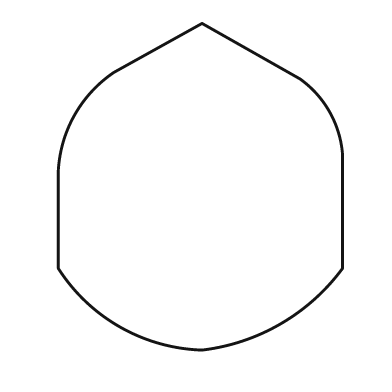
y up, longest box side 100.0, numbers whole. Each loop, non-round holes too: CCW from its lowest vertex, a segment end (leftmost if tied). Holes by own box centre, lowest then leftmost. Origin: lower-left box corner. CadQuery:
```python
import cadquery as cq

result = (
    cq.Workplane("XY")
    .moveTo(44.0, 0.0)
    .threePointArc((68.0, 8.0), (87.0, 25.0))
    .lineTo(87.0, 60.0)
    .threePointArc((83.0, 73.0), (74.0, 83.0))
    .lineTo(44.0, 100.0)
    .lineTo(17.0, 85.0)
    .threePointArc((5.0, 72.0), (0.0, 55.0))
    .lineTo(0.0, 25.0)
    .threePointArc((19.0, 7.0), (44.0, 0.0))
    .close()
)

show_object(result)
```